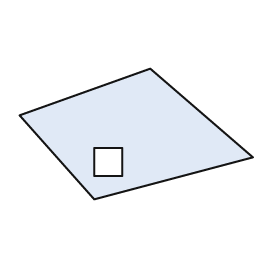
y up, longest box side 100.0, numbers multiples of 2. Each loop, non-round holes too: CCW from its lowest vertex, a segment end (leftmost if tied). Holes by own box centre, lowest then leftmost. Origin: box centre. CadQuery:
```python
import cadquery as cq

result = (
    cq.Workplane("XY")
    .moveTo(-18.0, -28.0)
    .lineTo(50.0, -10.0)
    .lineTo(6.0, 28.0)
    .lineTo(-50.0, 8.0)
    .close()
    .moveTo(-18.0, -18.0)
    .lineTo(-6.0, -18.0)
    .lineTo(-6.0, -6.0)
    .lineTo(-18.0, -6.0)
    .close()
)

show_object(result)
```